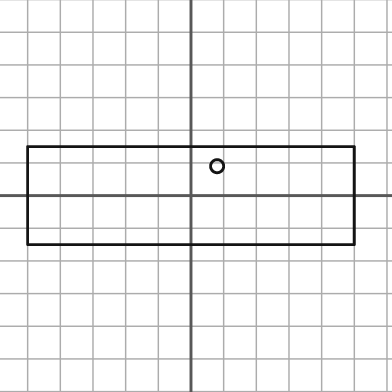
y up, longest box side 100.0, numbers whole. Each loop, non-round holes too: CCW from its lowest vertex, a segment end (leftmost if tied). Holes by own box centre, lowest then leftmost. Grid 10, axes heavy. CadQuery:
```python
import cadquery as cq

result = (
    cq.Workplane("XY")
    .moveTo(-50.0, -15.0)
    .lineTo(50.0, -15.0)
    .lineTo(50.0, 15.0)
    .lineTo(-50.0, 15.0)
    .close()
    .moveTo(8.0, 9.0)
    .circle(2.0)
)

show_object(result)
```